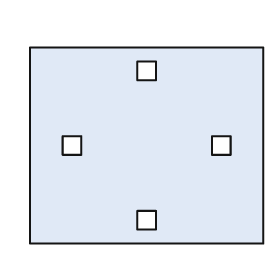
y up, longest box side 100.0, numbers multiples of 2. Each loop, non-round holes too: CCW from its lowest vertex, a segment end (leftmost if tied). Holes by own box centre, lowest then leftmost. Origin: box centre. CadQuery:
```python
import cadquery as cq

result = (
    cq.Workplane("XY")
    .moveTo(-50.0, -42.0)
    .lineTo(50.0, -42.0)
    .lineTo(50.0, 42.0)
    .lineTo(-50.0, 42.0)
    .close()
    .moveTo(-4.0, -36.0)
    .lineTo(4.0, -36.0)
    .lineTo(4.0, -28.0)
    .lineTo(-4.0, -28.0)
    .close()
    .moveTo(-36.0, -4.0)
    .lineTo(-28.0, -4.0)
    .lineTo(-28.0, 4.0)
    .lineTo(-36.0, 4.0)
    .close()
    .moveTo(28.0, -4.0)
    .lineTo(36.0, -4.0)
    .lineTo(36.0, 4.0)
    .lineTo(28.0, 4.0)
    .close()
    .moveTo(-4.0, 28.0)
    .lineTo(4.0, 28.0)
    .lineTo(4.0, 36.0)
    .lineTo(-4.0, 36.0)
    .close()
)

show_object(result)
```